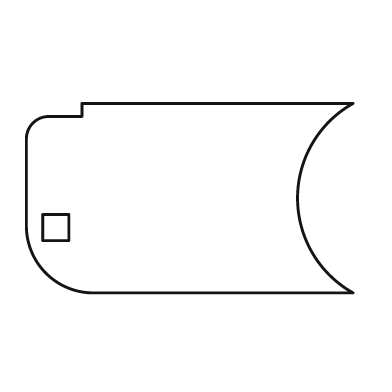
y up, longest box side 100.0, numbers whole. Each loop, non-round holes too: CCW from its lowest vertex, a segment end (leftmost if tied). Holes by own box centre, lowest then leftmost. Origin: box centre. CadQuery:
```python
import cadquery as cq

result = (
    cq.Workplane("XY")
    .moveTo(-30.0, -29.0)
    .lineTo(50.0, -29.0)
    .threePointArc((33.0, 0.0), (50.0, 29.0))
    .lineTo(-33.0, 29.0)
    .lineTo(-33.0, 25.0)
    .lineTo(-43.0, 25.0)
    .threePointArc((-48.0, 23.0), (-50.0, 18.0))
    .lineTo(-50.0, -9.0)
    .threePointArc((-44.0, -23.0), (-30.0, -29.0))
    .close()
    .moveTo(-45.0, -13.0)
    .lineTo(-37.0, -13.0)
    .lineTo(-37.0, -5.0)
    .lineTo(-45.0, -5.0)
    .close()
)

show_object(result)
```